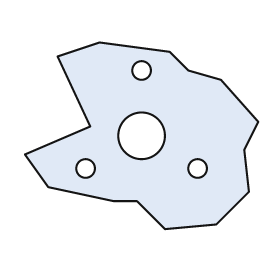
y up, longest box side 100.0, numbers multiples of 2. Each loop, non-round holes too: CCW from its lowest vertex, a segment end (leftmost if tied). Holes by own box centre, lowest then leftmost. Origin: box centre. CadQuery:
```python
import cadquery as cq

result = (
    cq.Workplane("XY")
    .moveTo(10.0, -40.0)
    .lineTo(32.0, -38.0)
    .lineTo(46.0, -24.0)
    .lineTo(44.0, -6.0)
    .lineTo(50.0, 6.0)
    .lineTo(34.0, 24.0)
    .lineTo(20.0, 28.0)
    .lineTo(12.0, 36.0)
    .lineTo(-18.0, 40.0)
    .lineTo(-36.0, 34.0)
    .lineTo(-22.0, 4.0)
    .lineTo(-50.0, -8.0)
    .lineTo(-40.0, -22.0)
    .lineTo(-12.0, -28.0)
    .lineTo(-2.0, -28.0)
    .close()
    .moveTo(-24.0, -14.0)
    .circle(4.0)
    .moveTo(24.0, -14.0)
    .circle(4.0)
    .moveTo(0.0, 0.0)
    .circle(10.0)
    .moveTo(0.0, 28.0)
    .circle(4.0)
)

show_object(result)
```